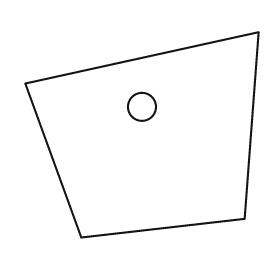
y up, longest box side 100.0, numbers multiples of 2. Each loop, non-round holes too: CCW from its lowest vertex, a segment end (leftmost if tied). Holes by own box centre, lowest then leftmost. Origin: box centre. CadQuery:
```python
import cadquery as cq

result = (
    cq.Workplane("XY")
    .moveTo(-26.0, -44.0)
    .lineTo(44.0, -36.0)
    .lineTo(50.0, 44.0)
    .lineTo(-50.0, 22.0)
    .close()
    .moveTo(0.0, 12.0)
    .circle(6.0)
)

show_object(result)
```